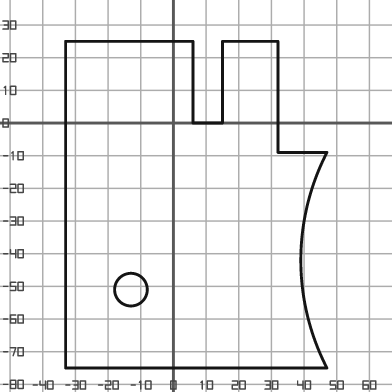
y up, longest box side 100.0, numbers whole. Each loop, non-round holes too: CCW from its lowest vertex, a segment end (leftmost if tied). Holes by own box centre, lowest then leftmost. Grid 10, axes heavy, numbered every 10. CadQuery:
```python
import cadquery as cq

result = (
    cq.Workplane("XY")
    .moveTo(-33.0, -75.0)
    .lineTo(47.0, -75.0)
    .threePointArc((39.0, -42.0), (47.0, -9.0))
    .lineTo(32.0, -9.0)
    .lineTo(32.0, 25.0)
    .lineTo(15.0, 25.0)
    .lineTo(15.0, 0.0)
    .lineTo(6.0, 0.0)
    .lineTo(6.0, 25.0)
    .lineTo(-33.0, 25.0)
    .close()
    .moveTo(-13.0, -51.0)
    .circle(5.0)
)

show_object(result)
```